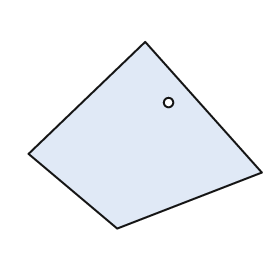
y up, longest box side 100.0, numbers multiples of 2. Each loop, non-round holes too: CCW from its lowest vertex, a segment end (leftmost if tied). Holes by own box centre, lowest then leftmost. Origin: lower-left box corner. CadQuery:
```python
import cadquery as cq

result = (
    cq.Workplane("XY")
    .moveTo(38.0, 0.0)
    .lineTo(100.0, 24.0)
    .lineTo(50.0, 80.0)
    .lineTo(0.0, 32.0)
    .close()
    .moveTo(60.0, 54.0)
    .circle(2.0)
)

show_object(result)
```